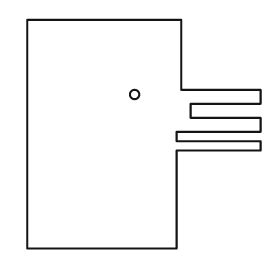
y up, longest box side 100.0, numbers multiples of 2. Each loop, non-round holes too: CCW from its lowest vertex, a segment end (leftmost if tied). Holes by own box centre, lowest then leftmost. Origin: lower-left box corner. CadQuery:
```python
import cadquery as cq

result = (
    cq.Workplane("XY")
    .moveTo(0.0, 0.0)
    .lineTo(64.0, 0.0)
    .lineTo(64.0, 42.0)
    .lineTo(100.0, 42.0)
    .lineTo(100.0, 46.0)
    .lineTo(64.0, 46.0)
    .lineTo(64.0, 50.0)
    .lineTo(100.0, 50.0)
    .lineTo(100.0, 56.0)
    .lineTo(70.0, 56.0)
    .lineTo(70.0, 62.0)
    .lineTo(100.0, 62.0)
    .lineTo(100.0, 68.0)
    .lineTo(66.0, 68.0)
    .lineTo(66.0, 98.0)
    .lineTo(0.0, 98.0)
    .close()
    .moveTo(46.0, 66.0)
    .circle(2.0)
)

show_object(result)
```